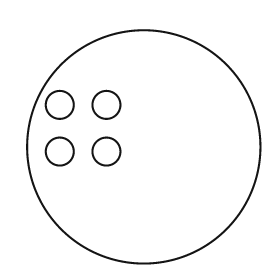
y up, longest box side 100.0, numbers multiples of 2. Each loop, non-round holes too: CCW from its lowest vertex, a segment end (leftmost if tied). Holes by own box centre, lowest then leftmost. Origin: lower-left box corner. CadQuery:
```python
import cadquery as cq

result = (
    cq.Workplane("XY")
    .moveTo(50.0, 50.0)
    .circle(50.0)
    .moveTo(14.0, 48.0)
    .circle(6.0)
    .moveTo(34.0, 48.0)
    .circle(6.0)
    .moveTo(14.0, 68.0)
    .circle(6.0)
    .moveTo(34.0, 68.0)
    .circle(6.0)
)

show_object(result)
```